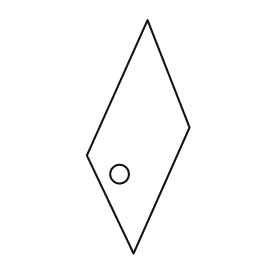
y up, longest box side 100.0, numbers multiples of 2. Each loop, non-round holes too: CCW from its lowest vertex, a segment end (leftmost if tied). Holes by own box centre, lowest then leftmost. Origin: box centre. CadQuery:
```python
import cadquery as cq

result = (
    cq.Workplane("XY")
    .moveTo(-2.0, -50.0)
    .lineTo(22.0, 4.0)
    .lineTo(4.0, 50.0)
    .lineTo(-22.0, -8.0)
    .close()
    .moveTo(-8.0, -16.0)
    .circle(4.0)
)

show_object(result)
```